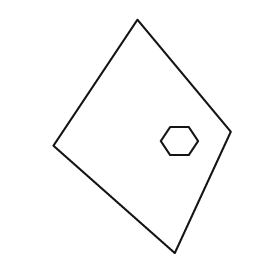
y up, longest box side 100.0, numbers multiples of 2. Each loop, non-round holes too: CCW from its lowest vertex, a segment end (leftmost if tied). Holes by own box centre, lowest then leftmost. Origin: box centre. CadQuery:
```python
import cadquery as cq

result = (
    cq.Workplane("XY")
    .moveTo(14.0, -50.0)
    .lineTo(38.0, 2.0)
    .lineTo(-2.0, 50.0)
    .lineTo(-38.0, -4.0)
    .close()
    .moveTo(12.0, -8.0)
    .lineTo(20.0, -8.0)
    .lineTo(24.0, -2.0)
    .lineTo(20.0, 4.0)
    .lineTo(12.0, 4.0)
    .lineTo(8.0, -2.0)
    .close()
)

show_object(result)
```